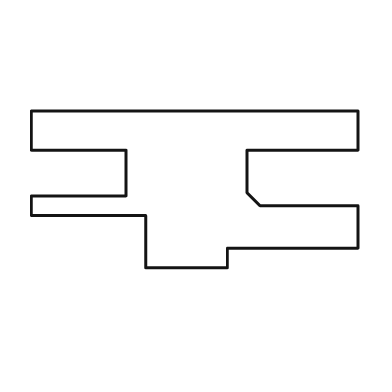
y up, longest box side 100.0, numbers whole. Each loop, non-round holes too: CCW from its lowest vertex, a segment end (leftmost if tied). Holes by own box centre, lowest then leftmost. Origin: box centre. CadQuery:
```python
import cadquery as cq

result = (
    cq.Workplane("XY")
    .moveTo(-15.0, -24.0)
    .lineTo(10.0, -24.0)
    .lineTo(10.0, -18.0)
    .lineTo(50.0, -18.0)
    .lineTo(50.0, -5.0)
    .lineTo(20.0, -5.0)
    .lineTo(16.0, -1.0)
    .lineTo(16.0, 12.0)
    .lineTo(50.0, 12.0)
    .lineTo(50.0, 24.0)
    .lineTo(-50.0, 24.0)
    .lineTo(-50.0, 12.0)
    .lineTo(-21.0, 12.0)
    .lineTo(-21.0, -2.0)
    .lineTo(-50.0, -2.0)
    .lineTo(-50.0, -8.0)
    .lineTo(-15.0, -8.0)
    .close()
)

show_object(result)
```